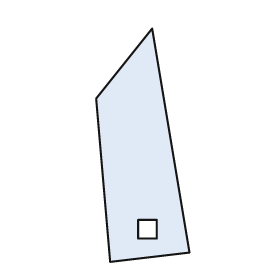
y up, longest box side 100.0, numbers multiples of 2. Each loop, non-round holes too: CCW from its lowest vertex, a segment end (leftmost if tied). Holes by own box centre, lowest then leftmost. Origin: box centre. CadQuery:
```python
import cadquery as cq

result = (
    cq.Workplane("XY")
    .moveTo(-14.0, -50.0)
    .lineTo(20.0, -46.0)
    .lineTo(4.0, 50.0)
    .lineTo(-20.0, 20.0)
    .close()
    .moveTo(-2.0, -40.0)
    .lineTo(6.0, -40.0)
    .lineTo(6.0, -32.0)
    .lineTo(-2.0, -32.0)
    .close()
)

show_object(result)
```